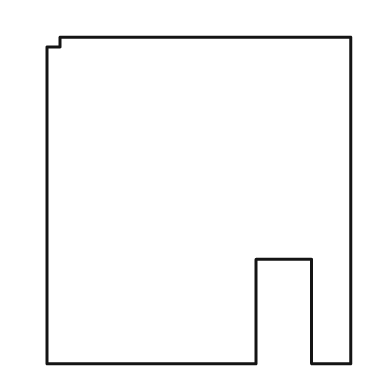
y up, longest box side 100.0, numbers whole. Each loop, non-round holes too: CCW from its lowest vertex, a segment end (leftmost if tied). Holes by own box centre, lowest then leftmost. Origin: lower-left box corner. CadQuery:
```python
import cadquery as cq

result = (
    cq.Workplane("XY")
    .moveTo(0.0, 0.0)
    .lineTo(64.0, 0.0)
    .lineTo(64.0, 32.0)
    .lineTo(81.0, 32.0)
    .lineTo(81.0, 0.0)
    .lineTo(93.0, 0.0)
    .lineTo(93.0, 100.0)
    .lineTo(4.0, 100.0)
    .lineTo(4.0, 97.0)
    .lineTo(0.0, 97.0)
    .close()
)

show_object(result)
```